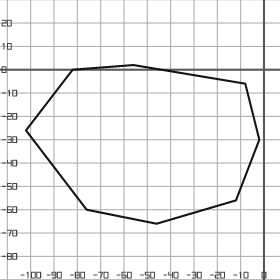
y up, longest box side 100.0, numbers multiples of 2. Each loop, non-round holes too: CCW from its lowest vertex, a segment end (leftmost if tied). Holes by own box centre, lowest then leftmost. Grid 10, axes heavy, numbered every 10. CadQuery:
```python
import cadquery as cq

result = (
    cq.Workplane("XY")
    .moveTo(-46.0, -66.0)
    .lineTo(-12.0, -56.0)
    .lineTo(-2.0, -30.0)
    .lineTo(-8.0, -6.0)
    .lineTo(-56.0, 2.0)
    .lineTo(-82.0, 0.0)
    .lineTo(-102.0, -26.0)
    .lineTo(-76.0, -60.0)
    .close()
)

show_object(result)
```